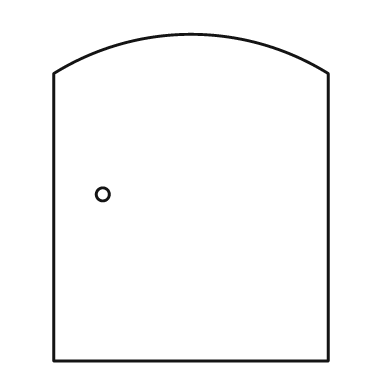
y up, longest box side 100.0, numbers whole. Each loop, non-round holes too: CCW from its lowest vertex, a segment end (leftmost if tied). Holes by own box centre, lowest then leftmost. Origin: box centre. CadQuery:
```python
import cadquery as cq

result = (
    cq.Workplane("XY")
    .moveTo(-42.0, -50.0)
    .lineTo(42.0, -50.0)
    .lineTo(42.0, 38.0)
    .threePointArc((0.0, 50.0), (-42.0, 38.0))
    .close()
    .moveTo(-27.0, 1.0)
    .circle(2.0)
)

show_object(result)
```